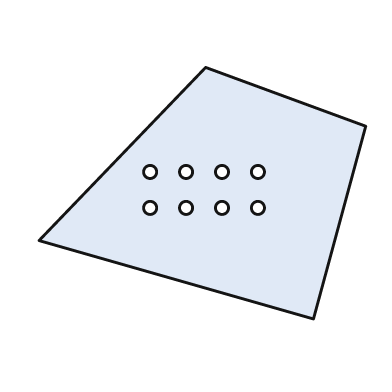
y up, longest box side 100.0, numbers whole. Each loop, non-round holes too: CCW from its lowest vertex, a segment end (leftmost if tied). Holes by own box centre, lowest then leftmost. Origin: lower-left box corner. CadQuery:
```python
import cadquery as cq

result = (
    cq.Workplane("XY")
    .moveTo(84.0, 0.0)
    .lineTo(100.0, 59.0)
    .lineTo(51.0, 77.0)
    .lineTo(0.0, 24.0)
    .close()
    .moveTo(34.0, 34.0)
    .circle(2.0)
    .moveTo(45.0, 34.0)
    .circle(2.0)
    .moveTo(56.0, 34.0)
    .circle(2.0)
    .moveTo(67.0, 34.0)
    .circle(2.0)
    .moveTo(34.0, 45.0)
    .circle(2.0)
    .moveTo(45.0, 45.0)
    .circle(2.0)
    .moveTo(56.0, 45.0)
    .circle(2.0)
    .moveTo(67.0, 45.0)
    .circle(2.0)
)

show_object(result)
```